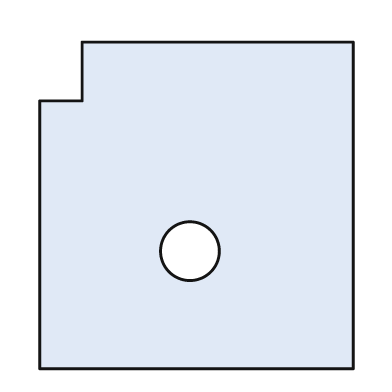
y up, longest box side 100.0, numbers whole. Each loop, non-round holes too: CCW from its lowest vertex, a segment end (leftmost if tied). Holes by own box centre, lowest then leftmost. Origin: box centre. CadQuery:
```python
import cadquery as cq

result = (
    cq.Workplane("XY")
    .moveTo(-48.0, -50.0)
    .lineTo(48.0, -50.0)
    .lineTo(48.0, 50.0)
    .lineTo(-35.0, 50.0)
    .lineTo(-35.0, 32.0)
    .lineTo(-48.0, 32.0)
    .close()
    .moveTo(-2.0, -14.0)
    .circle(9.0)
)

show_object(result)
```